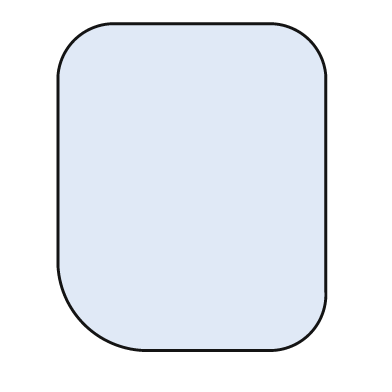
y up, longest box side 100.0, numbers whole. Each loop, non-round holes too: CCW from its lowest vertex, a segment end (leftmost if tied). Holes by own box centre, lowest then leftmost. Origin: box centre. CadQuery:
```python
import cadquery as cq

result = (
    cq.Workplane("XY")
    .moveTo(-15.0, -50.0)
    .lineTo(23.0, -50.0)
    .threePointArc((36.0, -45.0), (41.0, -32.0))
    .lineTo(41.0, 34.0)
    .threePointArc((36.0, 45.0), (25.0, 50.0))
    .lineTo(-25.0, 50.0)
    .threePointArc((-36.0, 45.0), (-41.0, 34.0))
    .lineTo(-41.0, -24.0)
    .threePointArc((-33.0, -42.0), (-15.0, -50.0))
    .close()
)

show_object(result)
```